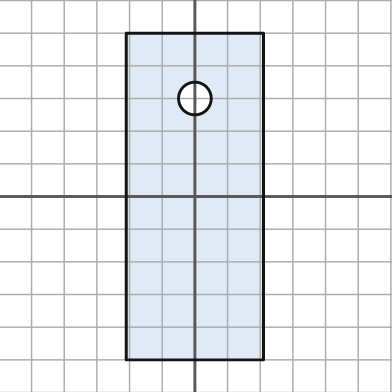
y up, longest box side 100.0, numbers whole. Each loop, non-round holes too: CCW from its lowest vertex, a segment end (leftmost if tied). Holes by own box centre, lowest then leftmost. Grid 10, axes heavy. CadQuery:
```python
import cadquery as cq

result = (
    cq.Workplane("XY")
    .moveTo(-21.0, -50.0)
    .lineTo(21.0, -50.0)
    .lineTo(21.0, 50.0)
    .lineTo(-21.0, 50.0)
    .close()
    .moveTo(0.0, 30.0)
    .circle(5.0)
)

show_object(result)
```